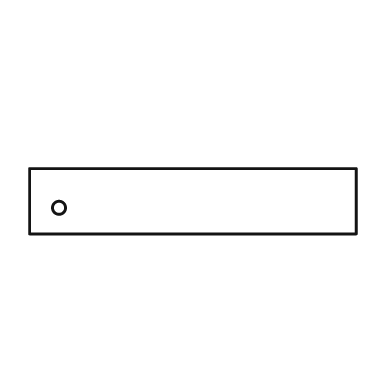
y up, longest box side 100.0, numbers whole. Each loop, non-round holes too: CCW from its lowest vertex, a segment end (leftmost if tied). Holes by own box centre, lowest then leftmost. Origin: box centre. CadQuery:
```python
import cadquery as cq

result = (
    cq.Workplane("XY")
    .moveTo(-50.0, -10.0)
    .lineTo(50.0, -10.0)
    .lineTo(50.0, 10.0)
    .lineTo(-50.0, 10.0)
    .close()
    .moveTo(-41.0, -2.0)
    .circle(2.0)
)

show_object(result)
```